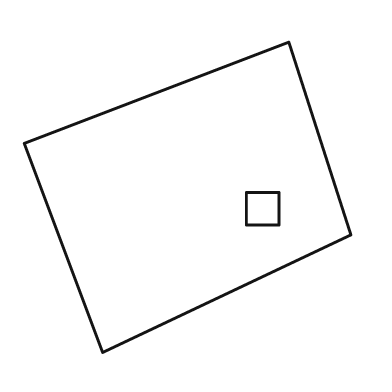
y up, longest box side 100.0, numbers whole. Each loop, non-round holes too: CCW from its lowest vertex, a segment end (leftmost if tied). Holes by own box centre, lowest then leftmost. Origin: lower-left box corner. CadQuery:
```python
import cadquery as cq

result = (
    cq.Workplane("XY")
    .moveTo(24.0, 0.0)
    .lineTo(100.0, 36.0)
    .lineTo(81.0, 95.0)
    .lineTo(0.0, 64.0)
    .close()
    .moveTo(68.0, 39.0)
    .lineTo(78.0, 39.0)
    .lineTo(78.0, 49.0)
    .lineTo(68.0, 49.0)
    .close()
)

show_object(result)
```